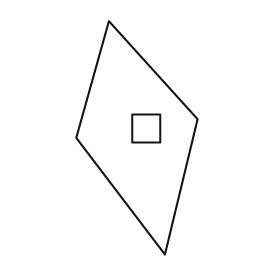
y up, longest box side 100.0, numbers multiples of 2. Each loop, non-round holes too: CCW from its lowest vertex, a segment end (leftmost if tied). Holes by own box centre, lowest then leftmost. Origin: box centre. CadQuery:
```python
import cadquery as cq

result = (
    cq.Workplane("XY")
    .moveTo(12.0, -50.0)
    .lineTo(26.0, 8.0)
    .lineTo(-12.0, 50.0)
    .lineTo(-26.0, 0.0)
    .close()
    .moveTo(-2.0, -2.0)
    .lineTo(10.0, -2.0)
    .lineTo(10.0, 10.0)
    .lineTo(-2.0, 10.0)
    .close()
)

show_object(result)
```